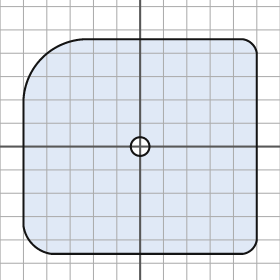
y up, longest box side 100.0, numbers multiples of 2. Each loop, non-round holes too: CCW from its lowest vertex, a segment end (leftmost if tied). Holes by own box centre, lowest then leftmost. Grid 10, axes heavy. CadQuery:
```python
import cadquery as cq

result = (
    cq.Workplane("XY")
    .moveTo(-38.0, -46.0)
    .lineTo(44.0, -46.0)
    .threePointArc((48.0, -44.0), (50.0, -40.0))
    .lineTo(50.0, 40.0)
    .threePointArc((48.0, 44.0), (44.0, 46.0))
    .lineTo(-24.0, 46.0)
    .threePointArc((-42.0, 38.0), (-50.0, 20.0))
    .lineTo(-50.0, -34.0)
    .threePointArc((-46.0, -42.0), (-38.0, -46.0))
    .close()
    .moveTo(0.0, 0.0)
    .circle(4.0)
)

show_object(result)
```